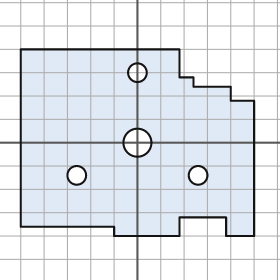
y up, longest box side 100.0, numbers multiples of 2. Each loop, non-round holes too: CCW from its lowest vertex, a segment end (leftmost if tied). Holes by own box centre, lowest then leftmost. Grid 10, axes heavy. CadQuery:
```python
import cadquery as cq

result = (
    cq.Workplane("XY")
    .moveTo(-10.0, -40.0)
    .lineTo(18.0, -40.0)
    .lineTo(18.0, -32.0)
    .lineTo(38.0, -32.0)
    .lineTo(38.0, -40.0)
    .lineTo(50.0, -40.0)
    .lineTo(50.0, 18.0)
    .lineTo(40.0, 18.0)
    .lineTo(40.0, 24.0)
    .lineTo(24.0, 24.0)
    .lineTo(24.0, 28.0)
    .lineTo(18.0, 28.0)
    .lineTo(18.0, 40.0)
    .lineTo(-50.0, 40.0)
    .lineTo(-50.0, -36.0)
    .lineTo(-10.0, -36.0)
    .close()
    .moveTo(-26.0, -14.0)
    .circle(4.0)
    .moveTo(26.0, -14.0)
    .circle(4.0)
    .moveTo(0.0, 0.0)
    .circle(6.0)
    .moveTo(0.0, 30.0)
    .circle(4.0)
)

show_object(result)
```